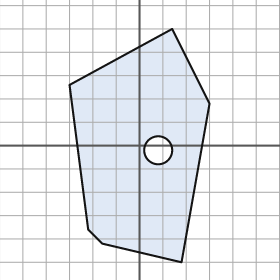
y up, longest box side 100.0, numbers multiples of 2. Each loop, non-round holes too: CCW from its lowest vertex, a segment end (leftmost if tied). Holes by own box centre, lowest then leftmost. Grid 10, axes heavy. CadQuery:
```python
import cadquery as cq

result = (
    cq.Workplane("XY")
    .moveTo(18.0, -50.0)
    .lineTo(30.0, 18.0)
    .lineTo(14.0, 50.0)
    .lineTo(-30.0, 26.0)
    .lineTo(-22.0, -36.0)
    .lineTo(-16.0, -42.0)
    .close()
    .moveTo(8.0, -2.0)
    .circle(6.0)
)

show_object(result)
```